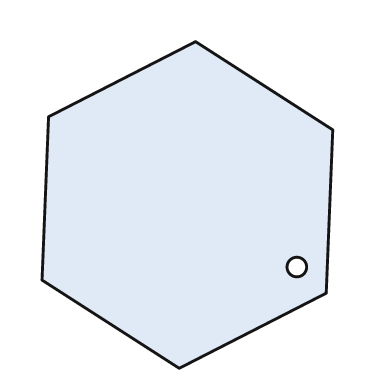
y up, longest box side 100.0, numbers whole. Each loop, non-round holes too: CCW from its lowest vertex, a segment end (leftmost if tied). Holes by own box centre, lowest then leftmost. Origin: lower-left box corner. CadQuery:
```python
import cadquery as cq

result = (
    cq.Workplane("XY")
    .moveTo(42.0, 0.0)
    .lineTo(87.0, 23.0)
    .lineTo(89.0, 73.0)
    .lineTo(47.0, 100.0)
    .lineTo(2.0, 77.0)
    .lineTo(0.0, 27.0)
    .close()
    .moveTo(78.0, 31.0)
    .circle(3.0)
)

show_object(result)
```